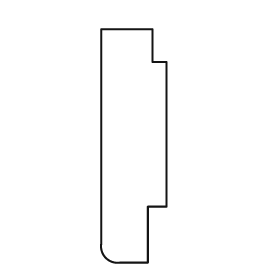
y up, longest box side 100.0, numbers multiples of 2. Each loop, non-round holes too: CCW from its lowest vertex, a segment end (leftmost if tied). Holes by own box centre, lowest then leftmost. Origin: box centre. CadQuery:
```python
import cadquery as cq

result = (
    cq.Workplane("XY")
    .moveTo(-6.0, -50.0)
    .lineTo(6.0, -50.0)
    .lineTo(6.0, -26.0)
    .lineTo(14.0, -26.0)
    .lineTo(14.0, 36.0)
    .lineTo(8.0, 36.0)
    .lineTo(8.0, 50.0)
    .lineTo(-14.0, 50.0)
    .lineTo(-14.0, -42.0)
    .threePointArc((-12.0, -48.0), (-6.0, -50.0))
    .close()
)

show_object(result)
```